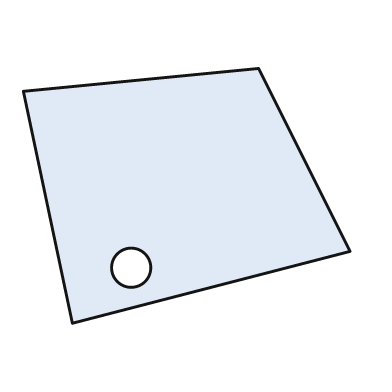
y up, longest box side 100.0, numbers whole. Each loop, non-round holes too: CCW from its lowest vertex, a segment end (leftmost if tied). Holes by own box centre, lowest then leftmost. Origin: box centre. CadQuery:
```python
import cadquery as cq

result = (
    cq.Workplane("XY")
    .moveTo(-35.0, -39.0)
    .lineTo(50.0, -17.0)
    .lineTo(22.0, 39.0)
    .lineTo(-50.0, 32.0)
    .close()
    .moveTo(-17.0, -22.0)
    .circle(6.0)
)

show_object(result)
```